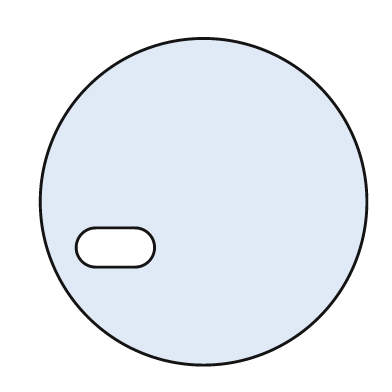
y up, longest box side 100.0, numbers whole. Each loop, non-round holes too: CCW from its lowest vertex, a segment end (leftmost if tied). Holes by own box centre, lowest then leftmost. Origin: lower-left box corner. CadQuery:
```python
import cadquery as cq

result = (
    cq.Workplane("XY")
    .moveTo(50.0, 50.0)
    .circle(50.0)
    .moveTo(17.0, 30.0)
    .lineTo(29.0, 30.0)
    .threePointArc((35.0, 36.0), (29.0, 42.0))
    .lineTo(17.0, 42.0)
    .threePointArc((11.0, 36.0), (17.0, 30.0))
    .close()
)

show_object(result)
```